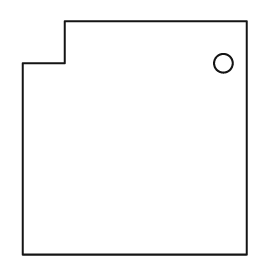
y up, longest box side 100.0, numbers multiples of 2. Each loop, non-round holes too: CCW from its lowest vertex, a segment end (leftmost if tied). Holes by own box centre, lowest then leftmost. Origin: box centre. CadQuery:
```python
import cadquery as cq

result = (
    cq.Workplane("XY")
    .moveTo(-48.0, -50.0)
    .lineTo(48.0, -50.0)
    .lineTo(48.0, 50.0)
    .lineTo(-30.0, 50.0)
    .lineTo(-30.0, 32.0)
    .lineTo(-48.0, 32.0)
    .close()
    .moveTo(38.0, 32.0)
    .circle(4.0)
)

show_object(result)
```